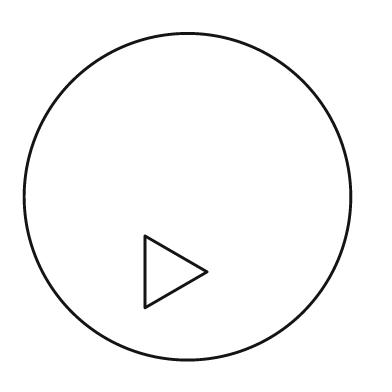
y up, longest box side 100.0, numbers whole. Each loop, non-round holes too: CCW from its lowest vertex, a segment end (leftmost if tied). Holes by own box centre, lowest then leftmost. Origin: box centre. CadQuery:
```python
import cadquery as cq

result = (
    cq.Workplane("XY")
    .moveTo(0.0, 0.0)
    .circle(50.0)
    .moveTo(-13.0, -34.0)
    .lineTo(6.0, -23.0)
    .lineTo(-13.0, -12.0)
    .close()
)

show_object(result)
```